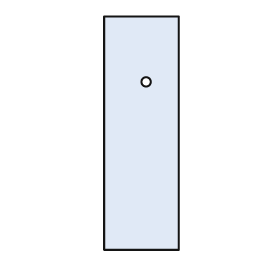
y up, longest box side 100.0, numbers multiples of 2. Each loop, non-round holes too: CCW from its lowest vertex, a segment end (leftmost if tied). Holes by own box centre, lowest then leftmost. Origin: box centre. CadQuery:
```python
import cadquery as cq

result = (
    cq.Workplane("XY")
    .moveTo(-16.0, -50.0)
    .lineTo(16.0, -50.0)
    .lineTo(16.0, 50.0)
    .lineTo(-16.0, 50.0)
    .close()
    .moveTo(2.0, 22.0)
    .circle(2.0)
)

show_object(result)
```